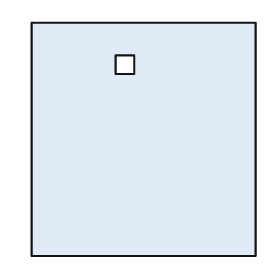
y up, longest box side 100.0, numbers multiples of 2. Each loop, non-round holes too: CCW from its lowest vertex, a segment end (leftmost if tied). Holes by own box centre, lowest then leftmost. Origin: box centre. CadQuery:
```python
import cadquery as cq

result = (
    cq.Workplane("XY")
    .moveTo(-48.0, -50.0)
    .lineTo(48.0, -50.0)
    .lineTo(48.0, 50.0)
    .lineTo(-48.0, 50.0)
    .close()
    .moveTo(-12.0, 28.0)
    .lineTo(-4.0, 28.0)
    .lineTo(-4.0, 36.0)
    .lineTo(-12.0, 36.0)
    .close()
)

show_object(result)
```